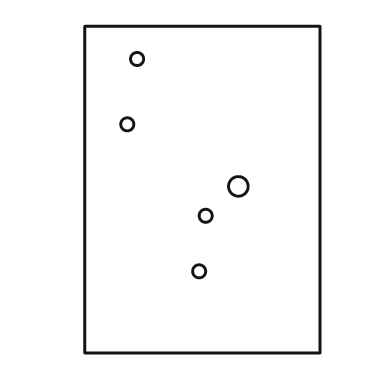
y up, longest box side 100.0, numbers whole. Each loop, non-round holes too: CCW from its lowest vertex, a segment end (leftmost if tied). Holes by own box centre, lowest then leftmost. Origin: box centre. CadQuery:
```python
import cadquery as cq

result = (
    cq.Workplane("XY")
    .moveTo(-36.0, -50.0)
    .lineTo(36.0, -50.0)
    .lineTo(36.0, 50.0)
    .lineTo(-36.0, 50.0)
    .close()
    .moveTo(-1.0, -25.0)
    .circle(2.0)
    .moveTo(1.0, -8.0)
    .circle(2.0)
    .moveTo(11.0, 1.0)
    .circle(3.0)
    .moveTo(-23.0, 20.0)
    .circle(2.0)
    .moveTo(-20.0, 40.0)
    .circle(2.0)
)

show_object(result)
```